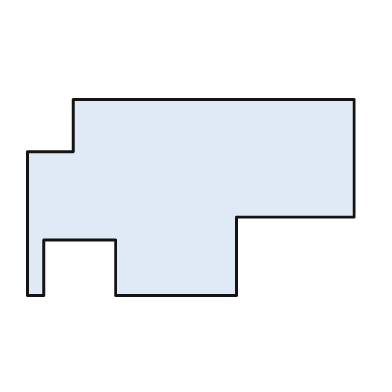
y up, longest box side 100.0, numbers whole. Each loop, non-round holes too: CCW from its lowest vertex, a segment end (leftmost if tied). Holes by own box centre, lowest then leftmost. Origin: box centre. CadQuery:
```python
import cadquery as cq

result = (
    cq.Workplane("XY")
    .moveTo(-50.0, -30.0)
    .lineTo(-45.0, -30.0)
    .lineTo(-45.0, -13.0)
    .lineTo(-23.0, -13.0)
    .lineTo(-23.0, -30.0)
    .lineTo(14.0, -30.0)
    .lineTo(14.0, -6.0)
    .lineTo(50.0, -6.0)
    .lineTo(50.0, 30.0)
    .lineTo(-36.0, 30.0)
    .lineTo(-36.0, 14.0)
    .lineTo(-50.0, 14.0)
    .close()
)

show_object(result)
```